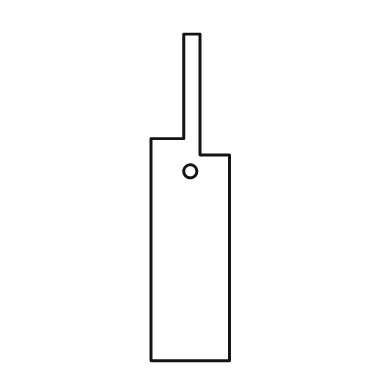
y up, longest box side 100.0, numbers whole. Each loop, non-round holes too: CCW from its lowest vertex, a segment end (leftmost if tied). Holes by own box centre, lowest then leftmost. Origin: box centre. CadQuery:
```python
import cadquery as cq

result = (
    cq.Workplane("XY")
    .moveTo(-12.0, -50.0)
    .lineTo(12.0, -50.0)
    .lineTo(12.0, 13.0)
    .lineTo(3.0, 13.0)
    .lineTo(3.0, 50.0)
    .lineTo(-2.0, 50.0)
    .lineTo(-2.0, 18.0)
    .lineTo(-12.0, 18.0)
    .close()
    .moveTo(0.0, 8.0)
    .circle(2.0)
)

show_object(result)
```